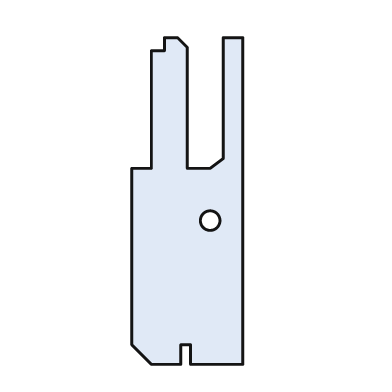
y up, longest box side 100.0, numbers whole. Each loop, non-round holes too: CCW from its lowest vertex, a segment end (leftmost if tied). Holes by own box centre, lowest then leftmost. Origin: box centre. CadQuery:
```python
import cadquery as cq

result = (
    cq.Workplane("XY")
    .moveTo(-11.0, -50.0)
    .lineTo(-2.0, -50.0)
    .lineTo(-2.0, -44.0)
    .lineTo(1.0, -44.0)
    .lineTo(1.0, -50.0)
    .lineTo(17.0, -50.0)
    .lineTo(17.0, 50.0)
    .lineTo(11.0, 50.0)
    .lineTo(11.0, 13.0)
    .lineTo(7.0, 10.0)
    .lineTo(0.0, 10.0)
    .lineTo(0.0, 47.0)
    .lineTo(-3.0, 50.0)
    .lineTo(-7.0, 50.0)
    .lineTo(-7.0, 46.0)
    .lineTo(-11.0, 46.0)
    .lineTo(-11.0, 10.0)
    .lineTo(-17.0, 10.0)
    .lineTo(-17.0, -44.0)
    .close()
    .moveTo(7.0, -6.0)
    .circle(3.0)
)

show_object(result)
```